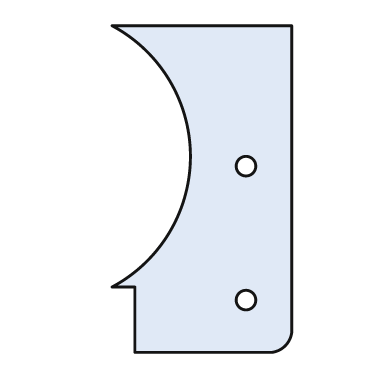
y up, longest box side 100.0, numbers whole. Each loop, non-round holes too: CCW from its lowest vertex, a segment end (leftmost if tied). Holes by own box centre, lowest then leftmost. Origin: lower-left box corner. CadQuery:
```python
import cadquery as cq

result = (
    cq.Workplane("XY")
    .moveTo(7.0, 0.0)
    .lineTo(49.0, 0.0)
    .threePointArc((53.0, 2.0), (55.0, 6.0))
    .lineTo(55.0, 100.0)
    .lineTo(0.0, 100.0)
    .threePointArc((24.0, 60.0), (0.0, 20.0))
    .lineTo(7.0, 20.0)
    .close()
    .moveTo(41.0, 16.0)
    .circle(3.0)
    .moveTo(41.0, 57.0)
    .circle(3.0)
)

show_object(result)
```